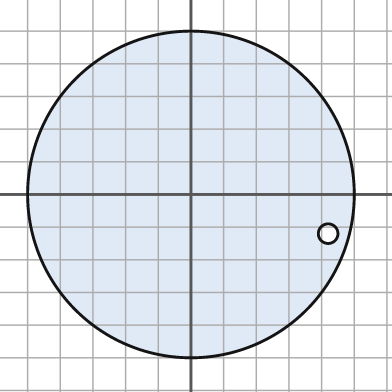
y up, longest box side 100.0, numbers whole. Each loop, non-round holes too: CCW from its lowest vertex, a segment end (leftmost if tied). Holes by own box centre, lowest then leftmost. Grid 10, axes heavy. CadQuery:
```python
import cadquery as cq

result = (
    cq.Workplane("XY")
    .moveTo(0.0, 0.0)
    .circle(50.0)
    .moveTo(42.0, -12.0)
    .circle(3.0)
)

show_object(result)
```